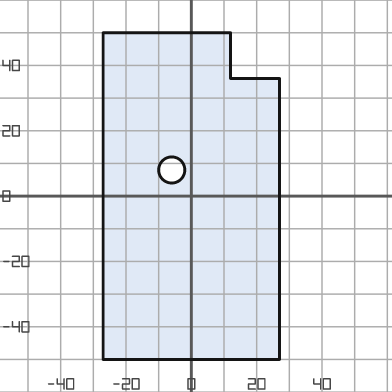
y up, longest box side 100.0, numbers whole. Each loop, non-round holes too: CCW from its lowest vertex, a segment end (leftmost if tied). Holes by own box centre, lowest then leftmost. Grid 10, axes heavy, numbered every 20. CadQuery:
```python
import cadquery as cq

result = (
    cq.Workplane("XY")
    .moveTo(-27.0, -50.0)
    .lineTo(27.0, -50.0)
    .lineTo(27.0, 36.0)
    .lineTo(12.0, 36.0)
    .lineTo(12.0, 50.0)
    .lineTo(-27.0, 50.0)
    .close()
    .moveTo(-6.0, 8.0)
    .circle(4.0)
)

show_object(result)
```